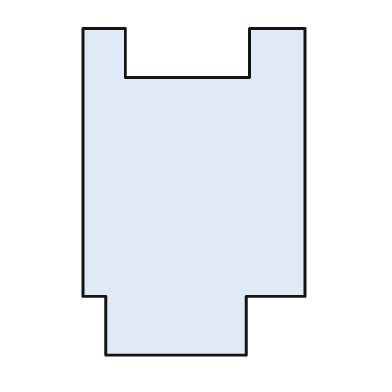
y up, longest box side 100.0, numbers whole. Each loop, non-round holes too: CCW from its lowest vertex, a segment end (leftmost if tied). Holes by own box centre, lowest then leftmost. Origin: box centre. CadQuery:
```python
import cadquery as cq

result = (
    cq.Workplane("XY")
    .moveTo(-27.0, -50.0)
    .lineTo(16.0, -50.0)
    .lineTo(16.0, -32.0)
    .lineTo(34.0, -32.0)
    .lineTo(34.0, 50.0)
    .lineTo(17.0, 50.0)
    .lineTo(17.0, 35.0)
    .lineTo(-21.0, 35.0)
    .lineTo(-21.0, 50.0)
    .lineTo(-34.0, 50.0)
    .lineTo(-34.0, -32.0)
    .lineTo(-27.0, -32.0)
    .close()
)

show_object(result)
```